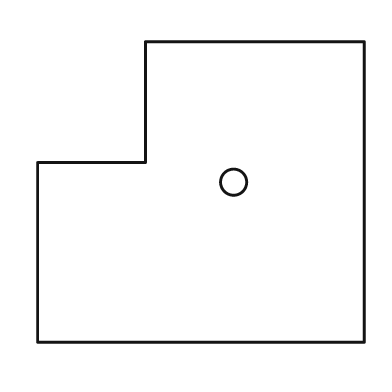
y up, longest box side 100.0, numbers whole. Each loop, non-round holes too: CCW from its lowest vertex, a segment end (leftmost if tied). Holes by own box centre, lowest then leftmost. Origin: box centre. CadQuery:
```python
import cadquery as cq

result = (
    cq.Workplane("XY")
    .moveTo(-50.0, -46.0)
    .lineTo(50.0, -46.0)
    .lineTo(50.0, 46.0)
    .lineTo(-17.0, 46.0)
    .lineTo(-17.0, 9.0)
    .lineTo(-50.0, 9.0)
    .close()
    .moveTo(10.0, 3.0)
    .circle(4.0)
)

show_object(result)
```